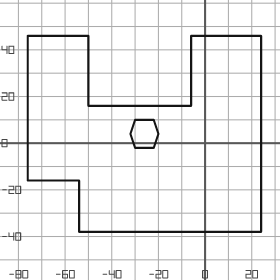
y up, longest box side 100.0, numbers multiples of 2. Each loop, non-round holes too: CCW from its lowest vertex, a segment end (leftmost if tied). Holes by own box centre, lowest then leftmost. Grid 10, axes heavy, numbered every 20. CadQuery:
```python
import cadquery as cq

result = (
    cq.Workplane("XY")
    .moveTo(-54.0, -38.0)
    .lineTo(24.0, -38.0)
    .lineTo(24.0, 46.0)
    .lineTo(-6.0, 46.0)
    .lineTo(-6.0, 16.0)
    .lineTo(-50.0, 16.0)
    .lineTo(-50.0, 46.0)
    .lineTo(-76.0, 46.0)
    .lineTo(-76.0, -16.0)
    .lineTo(-54.0, -16.0)
    .close()
    .moveTo(-30.0, -2.0)
    .lineTo(-22.0, -2.0)
    .lineTo(-20.0, 4.0)
    .lineTo(-22.0, 10.0)
    .lineTo(-30.0, 10.0)
    .lineTo(-32.0, 4.0)
    .close()
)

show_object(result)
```